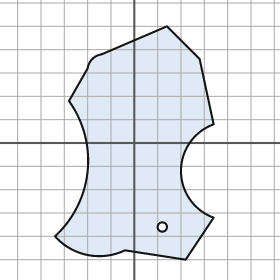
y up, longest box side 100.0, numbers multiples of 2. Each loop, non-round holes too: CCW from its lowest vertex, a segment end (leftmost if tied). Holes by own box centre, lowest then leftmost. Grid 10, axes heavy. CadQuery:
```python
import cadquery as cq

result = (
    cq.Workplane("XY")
    .moveTo(22.0, -50.0)
    .lineTo(34.0, -32.0)
    .threePointArc((20.0, -12.0), (34.0, 8.0))
    .lineTo(28.0, 36.0)
    .lineTo(14.0, 50.0)
    .lineTo(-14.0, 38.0)
    .threePointArc((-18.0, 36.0), (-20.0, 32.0))
    .lineTo(-28.0, 18.0)
    .threePointArc((-20.0, -12.0), (-34.0, -40.0))
    .threePointArc((-20.0, -48.0), (-4.0, -46.0))
    .close()
    .moveTo(12.0, -36.0)
    .circle(2.0)
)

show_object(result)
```